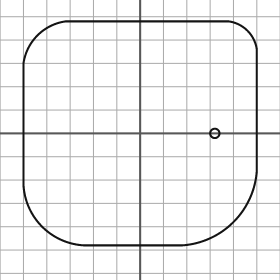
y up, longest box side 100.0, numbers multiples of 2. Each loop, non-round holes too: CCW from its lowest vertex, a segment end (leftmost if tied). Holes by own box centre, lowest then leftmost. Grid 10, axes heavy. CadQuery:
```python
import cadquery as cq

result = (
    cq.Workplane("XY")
    .moveTo(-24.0, -48.0)
    .lineTo(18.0, -48.0)
    .threePointArc((40.0, -38.0), (50.0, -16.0))
    .lineTo(50.0, 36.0)
    .threePointArc((46.0, 44.0), (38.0, 48.0))
    .lineTo(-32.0, 48.0)
    .threePointArc((-44.0, 42.0), (-50.0, 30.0))
    .lineTo(-50.0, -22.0)
    .threePointArc((-42.0, -40.0), (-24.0, -48.0))
    .close()
    .moveTo(32.0, 0.0)
    .circle(2.0)
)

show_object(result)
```